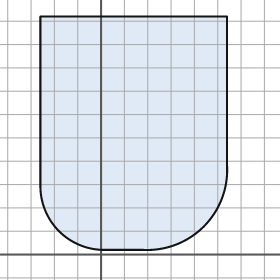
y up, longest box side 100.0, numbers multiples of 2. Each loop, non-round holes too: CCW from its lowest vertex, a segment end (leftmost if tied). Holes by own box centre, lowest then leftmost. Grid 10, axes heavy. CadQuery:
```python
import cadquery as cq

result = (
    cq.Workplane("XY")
    .moveTo(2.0, 2.0)
    .lineTo(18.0, 2.0)
    .threePointArc((44.0, 12.0), (54.0, 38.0))
    .lineTo(54.0, 102.0)
    .lineTo(-26.0, 102.0)
    .lineTo(-26.0, 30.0)
    .threePointArc((-18.0, 10.0), (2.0, 2.0))
    .close()
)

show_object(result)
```